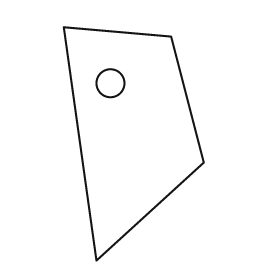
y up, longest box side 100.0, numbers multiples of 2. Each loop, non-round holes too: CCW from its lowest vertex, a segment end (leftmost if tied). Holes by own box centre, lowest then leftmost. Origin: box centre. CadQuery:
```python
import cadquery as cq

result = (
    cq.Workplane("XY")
    .moveTo(-16.0, -50.0)
    .lineTo(30.0, -8.0)
    .lineTo(16.0, 46.0)
    .lineTo(-30.0, 50.0)
    .close()
    .moveTo(-10.0, 26.0)
    .circle(6.0)
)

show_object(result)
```